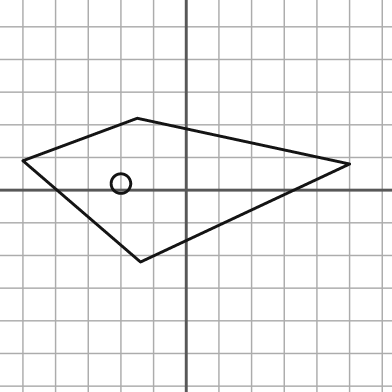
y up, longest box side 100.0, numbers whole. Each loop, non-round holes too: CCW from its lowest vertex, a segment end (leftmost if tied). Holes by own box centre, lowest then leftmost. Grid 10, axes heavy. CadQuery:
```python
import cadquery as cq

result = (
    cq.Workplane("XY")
    .moveTo(-14.0, -22.0)
    .lineTo(50.0, 8.0)
    .lineTo(-15.0, 22.0)
    .lineTo(-50.0, 9.0)
    .close()
    .moveTo(-20.0, 2.0)
    .circle(3.0)
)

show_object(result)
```